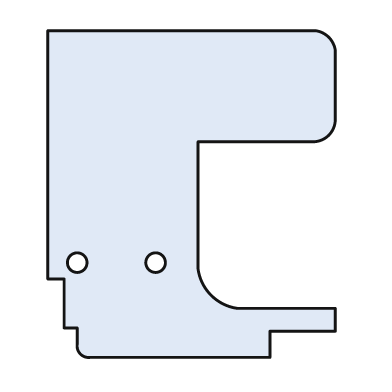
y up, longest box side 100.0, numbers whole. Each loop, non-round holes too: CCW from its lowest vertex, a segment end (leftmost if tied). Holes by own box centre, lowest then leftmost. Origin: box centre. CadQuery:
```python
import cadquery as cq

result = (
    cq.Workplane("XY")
    .moveTo(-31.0, -50.0)
    .lineTo(24.0, -50.0)
    .lineTo(24.0, -42.0)
    .lineTo(44.0, -42.0)
    .lineTo(44.0, -35.0)
    .lineTo(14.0, -35.0)
    .threePointArc((6.0, -31.0), (2.0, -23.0))
    .lineTo(2.0, 16.0)
    .lineTo(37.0, 16.0)
    .threePointArc((42.0, 18.0), (44.0, 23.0))
    .lineTo(44.0, 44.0)
    .threePointArc((42.0, 48.0), (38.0, 50.0))
    .lineTo(-44.0, 50.0)
    .lineTo(-44.0, -26.0)
    .lineTo(-39.0, -26.0)
    .lineTo(-39.0, -41.0)
    .lineTo(-35.0, -41.0)
    .lineTo(-35.0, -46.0)
    .threePointArc((-34.0, -49.0), (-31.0, -50.0))
    .close()
    .moveTo(-35.0, -21.0)
    .circle(3.0)
    .moveTo(-11.0, -21.0)
    .circle(3.0)
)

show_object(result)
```